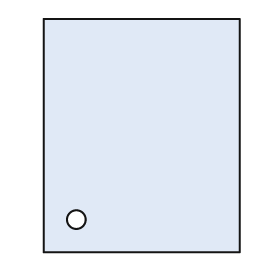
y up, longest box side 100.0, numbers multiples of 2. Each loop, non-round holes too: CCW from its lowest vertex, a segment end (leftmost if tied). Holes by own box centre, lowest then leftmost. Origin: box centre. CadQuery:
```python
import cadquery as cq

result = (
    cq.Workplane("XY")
    .moveTo(-42.0, -50.0)
    .lineTo(42.0, -50.0)
    .lineTo(42.0, 50.0)
    .lineTo(-42.0, 50.0)
    .close()
    .moveTo(-28.0, -36.0)
    .circle(4.0)
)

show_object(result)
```